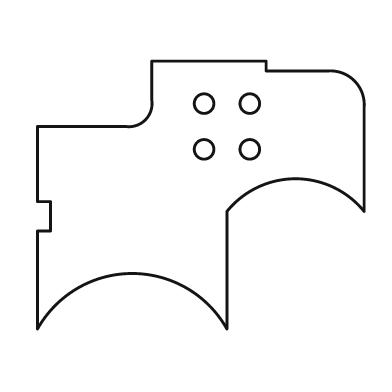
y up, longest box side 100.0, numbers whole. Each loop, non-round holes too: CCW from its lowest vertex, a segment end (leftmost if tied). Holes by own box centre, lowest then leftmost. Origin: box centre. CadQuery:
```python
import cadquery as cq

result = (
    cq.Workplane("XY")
    .moveTo(-50.0, -41.0)
    .threePointArc((-21.0, -24.0), (8.0, -41.0))
    .lineTo(8.0, -5.0)
    .threePointArc((29.0, 5.0), (50.0, -5.0))
    .lineTo(50.0, 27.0)
    .threePointArc((47.0, 35.0), (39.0, 38.0))
    .lineTo(20.0, 38.0)
    .lineTo(20.0, 41.0)
    .lineTo(-15.0, 41.0)
    .lineTo(-15.0, 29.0)
    .threePointArc((-17.0, 23.0), (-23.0, 21.0))
    .lineTo(-50.0, 21.0)
    .lineTo(-50.0, -2.0)
    .lineTo(-46.0, -2.0)
    .lineTo(-46.0, -11.0)
    .lineTo(-50.0, -11.0)
    .close()
    .moveTo(1.0, 14.0)
    .circle(3.0)
    .moveTo(15.0, 14.0)
    .circle(3.0)
    .moveTo(1.0, 28.0)
    .circle(3.0)
    .moveTo(15.0, 28.0)
    .circle(3.0)
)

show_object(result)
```